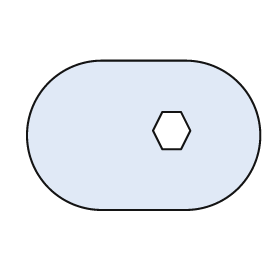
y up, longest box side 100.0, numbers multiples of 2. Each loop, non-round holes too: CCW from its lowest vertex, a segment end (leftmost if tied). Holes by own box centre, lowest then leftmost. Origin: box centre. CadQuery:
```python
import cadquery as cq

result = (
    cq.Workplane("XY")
    .moveTo(-18.0, -32.0)
    .lineTo(18.0, -32.0)
    .threePointArc((50.0, 0.0), (18.0, 32.0))
    .lineTo(-18.0, 32.0)
    .threePointArc((-50.0, 0.0), (-18.0, -32.0))
    .close()
    .moveTo(8.0, -6.0)
    .lineTo(16.0, -6.0)
    .lineTo(20.0, 2.0)
    .lineTo(16.0, 10.0)
    .lineTo(8.0, 10.0)
    .lineTo(4.0, 2.0)
    .close()
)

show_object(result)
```